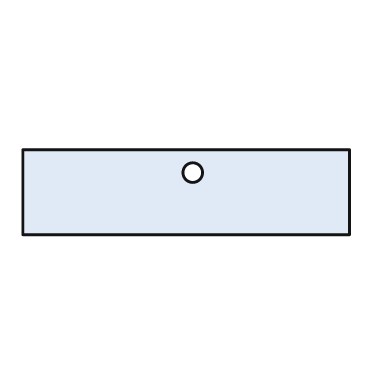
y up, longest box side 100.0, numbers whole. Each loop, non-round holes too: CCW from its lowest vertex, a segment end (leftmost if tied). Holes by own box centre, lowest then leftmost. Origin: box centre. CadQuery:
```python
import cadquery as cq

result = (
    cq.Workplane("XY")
    .moveTo(-50.0, -13.0)
    .lineTo(50.0, -13.0)
    .lineTo(50.0, 13.0)
    .lineTo(-50.0, 13.0)
    .close()
    .moveTo(2.0, 6.0)
    .circle(3.0)
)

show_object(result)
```